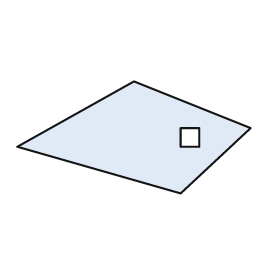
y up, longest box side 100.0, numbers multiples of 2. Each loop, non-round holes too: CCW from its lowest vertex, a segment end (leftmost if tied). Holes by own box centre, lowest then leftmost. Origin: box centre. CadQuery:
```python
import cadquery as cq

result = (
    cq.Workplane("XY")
    .moveTo(20.0, -24.0)
    .lineTo(50.0, 4.0)
    .lineTo(0.0, 24.0)
    .lineTo(-50.0, -4.0)
    .close()
    .moveTo(20.0, -4.0)
    .lineTo(28.0, -4.0)
    .lineTo(28.0, 4.0)
    .lineTo(20.0, 4.0)
    .close()
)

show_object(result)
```